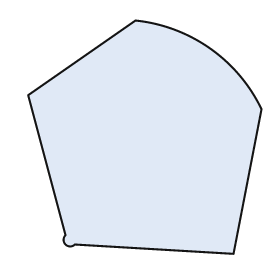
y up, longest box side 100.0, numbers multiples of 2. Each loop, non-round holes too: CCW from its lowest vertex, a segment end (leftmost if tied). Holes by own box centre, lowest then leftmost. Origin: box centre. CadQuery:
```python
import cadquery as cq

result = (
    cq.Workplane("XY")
    .moveTo(38.0, -50.0)
    .lineTo(50.0, 12.0)
    .threePointArc((28.0, 38.0), (-4.0, 50.0))
    .lineTo(-50.0, 18.0)
    .lineTo(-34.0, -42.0)
    .threePointArc((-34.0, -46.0), (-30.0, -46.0))
    .close()
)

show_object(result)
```